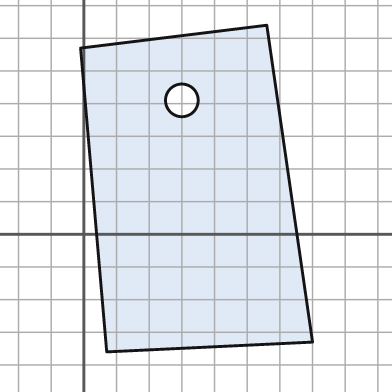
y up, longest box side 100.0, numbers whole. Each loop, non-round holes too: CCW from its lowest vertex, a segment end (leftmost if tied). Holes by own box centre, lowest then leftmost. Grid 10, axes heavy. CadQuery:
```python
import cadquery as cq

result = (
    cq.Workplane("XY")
    .moveTo(7.0, -36.0)
    .lineTo(70.0, -33.0)
    .lineTo(56.0, 64.0)
    .lineTo(-1.0, 57.0)
    .close()
    .moveTo(30.0, 41.0)
    .circle(5.0)
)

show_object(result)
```